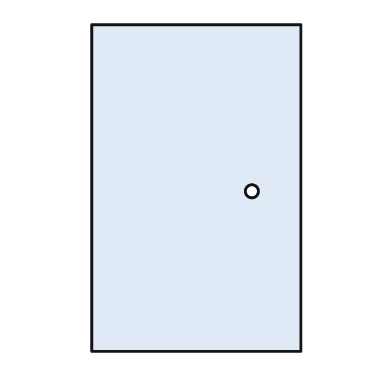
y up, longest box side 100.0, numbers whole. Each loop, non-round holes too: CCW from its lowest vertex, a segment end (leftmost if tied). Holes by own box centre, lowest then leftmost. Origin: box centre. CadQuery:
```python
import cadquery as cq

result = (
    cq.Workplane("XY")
    .moveTo(-32.0, -50.0)
    .lineTo(32.0, -50.0)
    .lineTo(32.0, 50.0)
    .lineTo(-32.0, 50.0)
    .close()
    .moveTo(17.0, -1.0)
    .circle(2.0)
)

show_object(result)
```